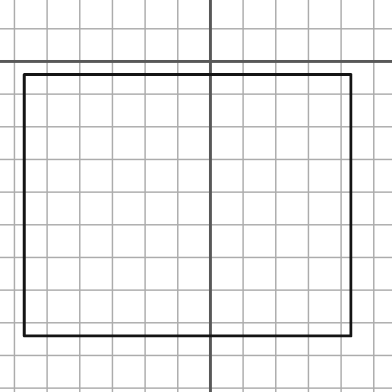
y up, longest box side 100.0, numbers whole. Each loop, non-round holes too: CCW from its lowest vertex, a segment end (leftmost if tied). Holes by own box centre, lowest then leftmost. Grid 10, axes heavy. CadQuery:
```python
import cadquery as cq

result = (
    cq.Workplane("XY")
    .moveTo(-57.0, -84.0)
    .lineTo(43.0, -84.0)
    .lineTo(43.0, -4.0)
    .lineTo(-57.0, -4.0)
    .close()
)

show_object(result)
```